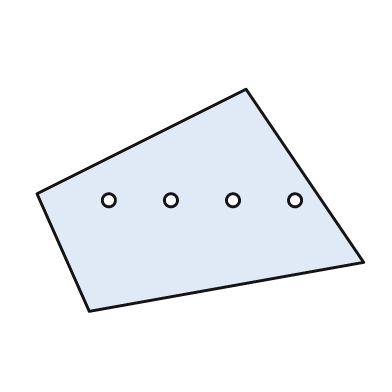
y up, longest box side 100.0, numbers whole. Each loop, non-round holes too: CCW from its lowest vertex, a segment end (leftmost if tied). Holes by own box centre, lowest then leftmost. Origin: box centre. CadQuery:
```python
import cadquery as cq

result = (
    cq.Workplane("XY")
    .moveTo(-34.0, -34.0)
    .lineTo(50.0, -19.0)
    .lineTo(14.0, 34.0)
    .lineTo(-50.0, 2.0)
    .close()
    .moveTo(-28.0, 0.0)
    .circle(2.0)
    .moveTo(-9.0, 0.0)
    .circle(2.0)
    .moveTo(10.0, 0.0)
    .circle(2.0)
    .moveTo(29.0, 0.0)
    .circle(2.0)
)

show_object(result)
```